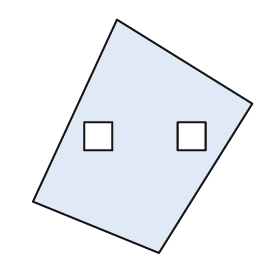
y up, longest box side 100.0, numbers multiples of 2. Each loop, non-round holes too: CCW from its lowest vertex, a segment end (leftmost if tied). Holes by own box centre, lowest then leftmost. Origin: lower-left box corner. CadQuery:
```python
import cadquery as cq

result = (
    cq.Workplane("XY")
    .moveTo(54.0, 0.0)
    .lineTo(94.0, 64.0)
    .lineTo(36.0, 100.0)
    .lineTo(0.0, 22.0)
    .close()
    .moveTo(22.0, 44.0)
    .lineTo(34.0, 44.0)
    .lineTo(34.0, 56.0)
    .lineTo(22.0, 56.0)
    .close()
    .moveTo(62.0, 44.0)
    .lineTo(74.0, 44.0)
    .lineTo(74.0, 56.0)
    .lineTo(62.0, 56.0)
    .close()
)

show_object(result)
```